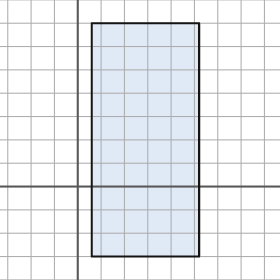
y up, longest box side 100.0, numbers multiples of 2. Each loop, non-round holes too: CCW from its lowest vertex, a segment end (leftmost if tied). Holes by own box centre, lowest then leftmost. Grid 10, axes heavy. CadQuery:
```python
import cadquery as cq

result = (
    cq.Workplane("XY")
    .moveTo(6.0, -30.0)
    .lineTo(52.0, -30.0)
    .lineTo(52.0, 70.0)
    .lineTo(6.0, 70.0)
    .close()
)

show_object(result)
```